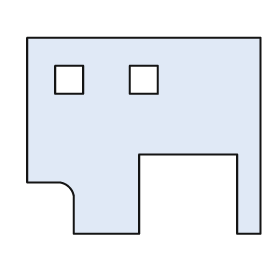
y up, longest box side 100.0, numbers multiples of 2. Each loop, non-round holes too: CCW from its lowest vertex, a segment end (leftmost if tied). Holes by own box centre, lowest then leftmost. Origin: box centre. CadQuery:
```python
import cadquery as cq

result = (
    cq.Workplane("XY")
    .moveTo(-30.0, -42.0)
    .lineTo(-2.0, -42.0)
    .lineTo(-2.0, -8.0)
    .lineTo(40.0, -8.0)
    .lineTo(40.0, -42.0)
    .lineTo(50.0, -42.0)
    .lineTo(50.0, 42.0)
    .lineTo(-50.0, 42.0)
    .lineTo(-50.0, -20.0)
    .lineTo(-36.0, -20.0)
    .threePointArc((-32.0, -22.0), (-30.0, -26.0))
    .close()
    .moveTo(-38.0, 18.0)
    .lineTo(-26.0, 18.0)
    .lineTo(-26.0, 30.0)
    .lineTo(-38.0, 30.0)
    .close()
    .moveTo(-6.0, 18.0)
    .lineTo(6.0, 18.0)
    .lineTo(6.0, 30.0)
    .lineTo(-6.0, 30.0)
    .close()
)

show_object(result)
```